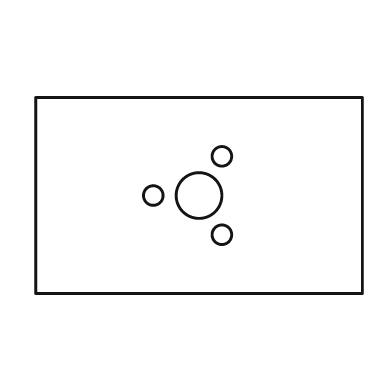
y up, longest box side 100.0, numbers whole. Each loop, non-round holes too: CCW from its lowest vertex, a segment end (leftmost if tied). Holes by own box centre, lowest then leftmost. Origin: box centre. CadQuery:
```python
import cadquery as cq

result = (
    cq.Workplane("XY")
    .moveTo(-50.0, -30.0)
    .lineTo(50.0, -30.0)
    .lineTo(50.0, 30.0)
    .lineTo(-50.0, 30.0)
    .close()
    .moveTo(7.0, -12.0)
    .circle(3.0)
    .moveTo(-14.0, 0.0)
    .circle(3.0)
    .moveTo(0.0, 0.0)
    .circle(7.0)
    .moveTo(7.0, 12.0)
    .circle(3.0)
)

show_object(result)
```